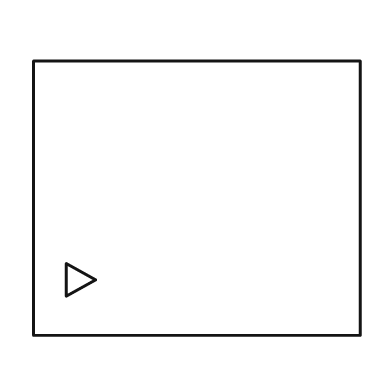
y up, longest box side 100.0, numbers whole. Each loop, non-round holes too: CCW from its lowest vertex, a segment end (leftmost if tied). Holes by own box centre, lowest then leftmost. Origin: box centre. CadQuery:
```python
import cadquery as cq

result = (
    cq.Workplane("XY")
    .moveTo(-50.0, -42.0)
    .lineTo(50.0, -42.0)
    .lineTo(50.0, 42.0)
    .lineTo(-50.0, 42.0)
    .close()
    .moveTo(-40.0, -30.0)
    .lineTo(-31.0, -25.0)
    .lineTo(-40.0, -20.0)
    .close()
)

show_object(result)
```